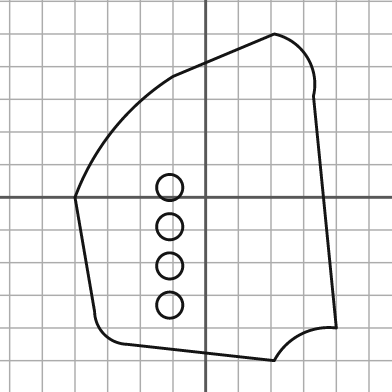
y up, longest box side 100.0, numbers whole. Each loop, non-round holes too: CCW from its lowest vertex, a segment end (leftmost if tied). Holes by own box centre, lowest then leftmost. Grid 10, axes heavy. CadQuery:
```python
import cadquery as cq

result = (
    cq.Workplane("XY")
    .moveTo(21.0, -50.0)
    .threePointArc((29.0, -42.0), (40.0, -40.0))
    .lineTo(33.0, 31.0)
    .threePointArc((31.0, 43.0), (21.0, 50.0))
    .lineTo(-10.0, 37.0)
    .threePointArc((-28.0, 21.0), (-40.0, 0.0))
    .lineTo(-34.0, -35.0)
    .threePointArc((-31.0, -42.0), (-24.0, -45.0))
    .close()
    .moveTo(-11.0, -33.0)
    .circle(4.0)
    .moveTo(-11.0, -21.0)
    .circle(4.0)
    .moveTo(-11.0, -9.0)
    .circle(4.0)
    .moveTo(-11.0, 3.0)
    .circle(4.0)
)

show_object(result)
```